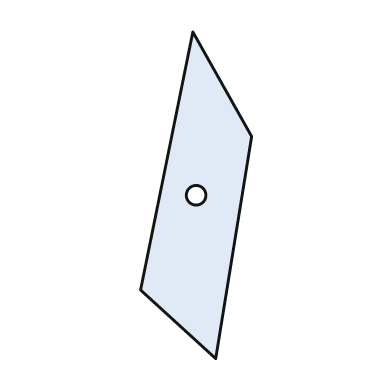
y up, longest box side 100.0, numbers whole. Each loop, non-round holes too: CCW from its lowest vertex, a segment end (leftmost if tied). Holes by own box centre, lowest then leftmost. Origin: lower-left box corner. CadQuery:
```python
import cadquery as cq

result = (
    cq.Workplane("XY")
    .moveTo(23.0, 0.0)
    .lineTo(34.0, 68.0)
    .lineTo(16.0, 100.0)
    .lineTo(0.0, 21.0)
    .close()
    .moveTo(17.0, 50.0)
    .circle(3.0)
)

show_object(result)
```